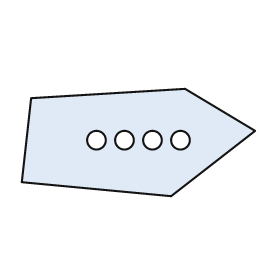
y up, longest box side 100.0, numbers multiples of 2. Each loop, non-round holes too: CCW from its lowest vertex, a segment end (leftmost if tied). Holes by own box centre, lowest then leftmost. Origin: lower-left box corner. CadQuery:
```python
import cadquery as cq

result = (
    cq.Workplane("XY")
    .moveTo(64.0, 0.0)
    .lineTo(100.0, 28.0)
    .lineTo(70.0, 46.0)
    .lineTo(4.0, 42.0)
    .lineTo(0.0, 6.0)
    .close()
    .moveTo(32.0, 24.0)
    .circle(4.0)
    .moveTo(44.0, 24.0)
    .circle(4.0)
    .moveTo(56.0, 24.0)
    .circle(4.0)
    .moveTo(68.0, 24.0)
    .circle(4.0)
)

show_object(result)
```